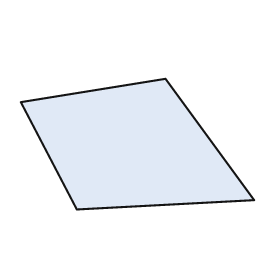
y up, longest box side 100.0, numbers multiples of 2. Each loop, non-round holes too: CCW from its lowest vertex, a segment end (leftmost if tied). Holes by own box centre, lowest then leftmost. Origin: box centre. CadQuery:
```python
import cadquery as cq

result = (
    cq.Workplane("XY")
    .moveTo(-26.0, -28.0)
    .lineTo(50.0, -24.0)
    .lineTo(12.0, 28.0)
    .lineTo(-50.0, 18.0)
    .close()
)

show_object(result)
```